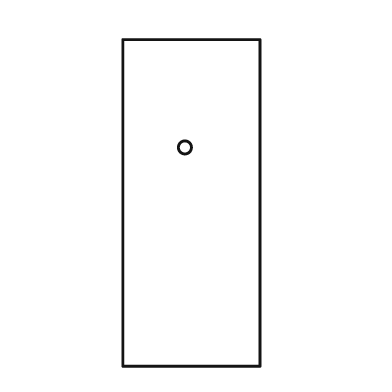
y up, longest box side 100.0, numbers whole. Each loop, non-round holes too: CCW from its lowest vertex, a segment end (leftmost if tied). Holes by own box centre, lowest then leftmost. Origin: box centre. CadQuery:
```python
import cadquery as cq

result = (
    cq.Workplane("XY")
    .moveTo(-21.0, -50.0)
    .lineTo(21.0, -50.0)
    .lineTo(21.0, 50.0)
    .lineTo(-21.0, 50.0)
    .close()
    .moveTo(-2.0, 17.0)
    .circle(2.0)
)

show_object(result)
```